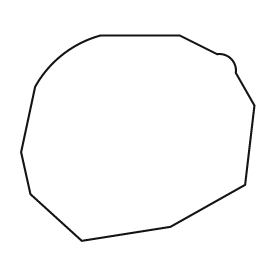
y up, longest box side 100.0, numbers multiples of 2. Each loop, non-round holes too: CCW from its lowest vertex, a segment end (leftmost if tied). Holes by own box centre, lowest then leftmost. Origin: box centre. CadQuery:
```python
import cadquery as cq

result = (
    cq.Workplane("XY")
    .moveTo(-24.0, -44.0)
    .lineTo(14.0, -38.0)
    .lineTo(46.0, -20.0)
    .lineTo(50.0, 14.0)
    .lineTo(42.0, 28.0)
    .threePointArc((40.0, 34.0), (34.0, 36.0))
    .lineTo(18.0, 44.0)
    .lineTo(-16.0, 44.0)
    .threePointArc((-32.0, 36.0), (-44.0, 22.0))
    .lineTo(-50.0, -6.0)
    .lineTo(-46.0, -24.0)
    .close()
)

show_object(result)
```